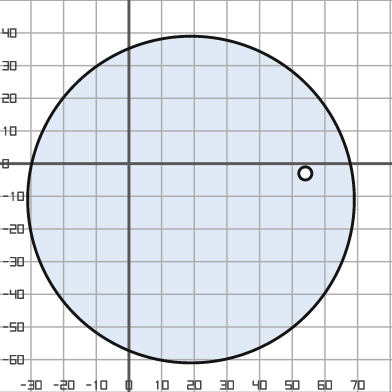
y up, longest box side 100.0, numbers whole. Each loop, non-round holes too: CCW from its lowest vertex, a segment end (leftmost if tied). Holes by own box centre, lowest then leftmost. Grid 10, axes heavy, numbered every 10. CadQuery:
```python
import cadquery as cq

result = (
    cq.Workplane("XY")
    .moveTo(19.0, -11.0)
    .circle(50.0)
    .moveTo(54.0, -3.0)
    .circle(2.0)
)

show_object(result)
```